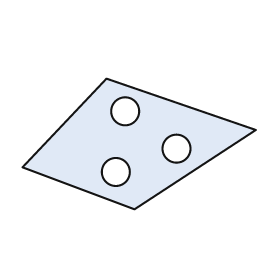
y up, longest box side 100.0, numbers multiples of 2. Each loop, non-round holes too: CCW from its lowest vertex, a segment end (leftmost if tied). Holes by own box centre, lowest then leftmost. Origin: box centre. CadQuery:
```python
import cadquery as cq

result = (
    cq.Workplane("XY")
    .moveTo(-2.0, -28.0)
    .lineTo(50.0, 6.0)
    .lineTo(-14.0, 28.0)
    .lineTo(-50.0, -10.0)
    .close()
    .moveTo(-10.0, -12.0)
    .circle(6.0)
    .moveTo(16.0, -2.0)
    .circle(6.0)
    .moveTo(-6.0, 14.0)
    .circle(6.0)
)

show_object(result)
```